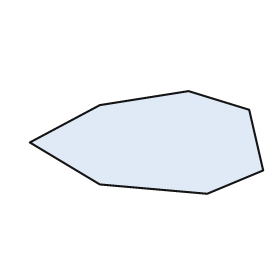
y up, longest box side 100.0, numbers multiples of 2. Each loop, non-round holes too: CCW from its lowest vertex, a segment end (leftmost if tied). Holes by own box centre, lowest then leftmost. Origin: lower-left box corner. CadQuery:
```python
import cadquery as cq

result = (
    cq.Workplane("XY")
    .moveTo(76.0, 0.0)
    .lineTo(100.0, 10.0)
    .lineTo(94.0, 36.0)
    .lineTo(68.0, 44.0)
    .lineTo(30.0, 38.0)
    .lineTo(0.0, 22.0)
    .lineTo(30.0, 4.0)
    .close()
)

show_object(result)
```